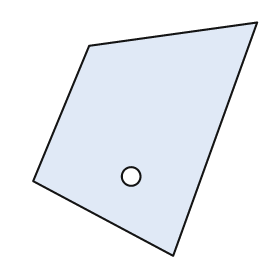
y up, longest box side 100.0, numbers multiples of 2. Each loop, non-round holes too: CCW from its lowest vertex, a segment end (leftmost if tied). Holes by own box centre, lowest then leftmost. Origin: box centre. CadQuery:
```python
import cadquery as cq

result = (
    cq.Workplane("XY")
    .moveTo(12.0, -50.0)
    .lineTo(48.0, 50.0)
    .lineTo(-24.0, 40.0)
    .lineTo(-48.0, -18.0)
    .close()
    .moveTo(-6.0, -16.0)
    .circle(4.0)
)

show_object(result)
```